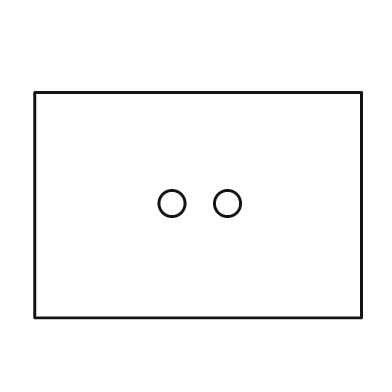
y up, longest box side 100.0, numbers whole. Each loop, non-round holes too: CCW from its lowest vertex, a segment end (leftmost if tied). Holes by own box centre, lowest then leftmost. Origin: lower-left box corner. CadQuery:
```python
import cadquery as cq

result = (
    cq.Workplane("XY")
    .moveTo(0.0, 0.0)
    .lineTo(100.0, 0.0)
    .lineTo(100.0, 69.0)
    .lineTo(0.0, 69.0)
    .close()
    .moveTo(42.0, 35.0)
    .circle(4.0)
    .moveTo(59.0, 35.0)
    .circle(4.0)
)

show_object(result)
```